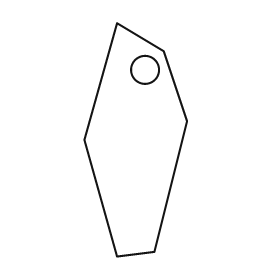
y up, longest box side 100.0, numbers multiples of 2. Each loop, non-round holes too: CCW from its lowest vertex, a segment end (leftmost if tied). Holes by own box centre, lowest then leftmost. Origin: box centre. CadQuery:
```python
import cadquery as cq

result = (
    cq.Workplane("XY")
    .moveTo(-8.0, -50.0)
    .lineTo(8.0, -48.0)
    .lineTo(22.0, 8.0)
    .lineTo(12.0, 38.0)
    .lineTo(-8.0, 50.0)
    .lineTo(-22.0, 0.0)
    .close()
    .moveTo(4.0, 30.0)
    .circle(6.0)
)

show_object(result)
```